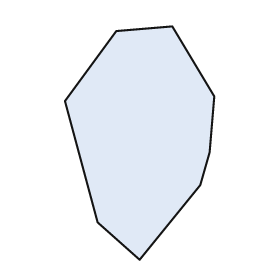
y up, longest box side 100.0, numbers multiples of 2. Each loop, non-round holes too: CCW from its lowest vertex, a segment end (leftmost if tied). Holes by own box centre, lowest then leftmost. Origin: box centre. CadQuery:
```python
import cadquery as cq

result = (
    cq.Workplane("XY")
    .moveTo(0.0, -50.0)
    .lineTo(26.0, -18.0)
    .lineTo(30.0, -4.0)
    .lineTo(32.0, 20.0)
    .lineTo(14.0, 50.0)
    .lineTo(-10.0, 48.0)
    .lineTo(-32.0, 18.0)
    .lineTo(-18.0, -34.0)
    .close()
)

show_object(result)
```